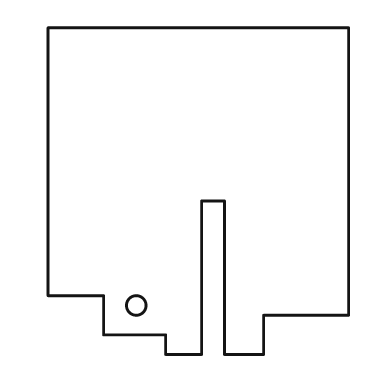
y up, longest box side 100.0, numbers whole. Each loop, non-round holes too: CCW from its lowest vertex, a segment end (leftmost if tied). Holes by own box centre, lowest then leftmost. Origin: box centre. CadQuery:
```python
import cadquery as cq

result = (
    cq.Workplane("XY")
    .moveTo(-10.0, -50.0)
    .lineTo(1.0, -50.0)
    .lineTo(1.0, -3.0)
    .lineTo(8.0, -3.0)
    .lineTo(8.0, -50.0)
    .lineTo(20.0, -50.0)
    .lineTo(20.0, -38.0)
    .lineTo(46.0, -38.0)
    .lineTo(46.0, 50.0)
    .lineTo(-46.0, 50.0)
    .lineTo(-46.0, -32.0)
    .lineTo(-29.0, -32.0)
    .lineTo(-29.0, -44.0)
    .lineTo(-10.0, -44.0)
    .close()
    .moveTo(-19.0, -35.0)
    .circle(3.0)
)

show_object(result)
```